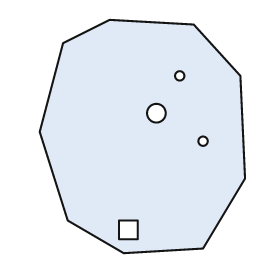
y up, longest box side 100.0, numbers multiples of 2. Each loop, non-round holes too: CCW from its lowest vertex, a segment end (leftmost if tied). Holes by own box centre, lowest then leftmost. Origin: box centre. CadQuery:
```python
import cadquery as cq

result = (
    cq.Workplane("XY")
    .moveTo(-8.0, -50.0)
    .lineTo(26.0, -48.0)
    .lineTo(44.0, -18.0)
    .lineTo(42.0, 26.0)
    .lineTo(22.0, 48.0)
    .lineTo(-14.0, 50.0)
    .lineTo(-34.0, 40.0)
    .lineTo(-44.0, 2.0)
    .lineTo(-32.0, -36.0)
    .close()
    .moveTo(-10.0, -44.0)
    .lineTo(-2.0, -44.0)
    .lineTo(-2.0, -36.0)
    .lineTo(-10.0, -36.0)
    .close()
    .moveTo(26.0, -2.0)
    .circle(2.0)
    .moveTo(6.0, 10.0)
    .circle(4.0)
    .moveTo(16.0, 26.0)
    .circle(2.0)
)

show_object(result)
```